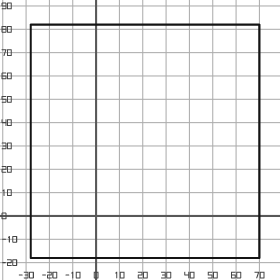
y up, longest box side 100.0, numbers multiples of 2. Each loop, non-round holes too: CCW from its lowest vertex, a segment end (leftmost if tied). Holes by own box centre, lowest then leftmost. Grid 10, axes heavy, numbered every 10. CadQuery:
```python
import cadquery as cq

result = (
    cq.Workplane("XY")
    .moveTo(-28.0, -18.0)
    .lineTo(70.0, -18.0)
    .lineTo(70.0, 82.0)
    .lineTo(-28.0, 82.0)
    .close()
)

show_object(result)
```